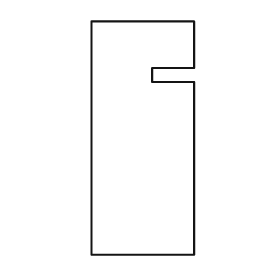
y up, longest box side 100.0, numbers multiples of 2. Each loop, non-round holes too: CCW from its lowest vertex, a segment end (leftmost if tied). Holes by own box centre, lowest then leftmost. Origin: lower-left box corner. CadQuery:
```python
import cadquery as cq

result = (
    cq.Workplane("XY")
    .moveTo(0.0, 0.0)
    .lineTo(44.0, 0.0)
    .lineTo(44.0, 74.0)
    .lineTo(26.0, 74.0)
    .lineTo(26.0, 80.0)
    .lineTo(44.0, 80.0)
    .lineTo(44.0, 100.0)
    .lineTo(0.0, 100.0)
    .close()
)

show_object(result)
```